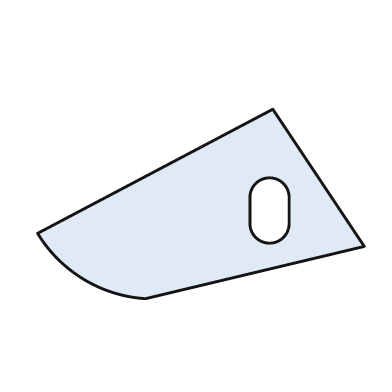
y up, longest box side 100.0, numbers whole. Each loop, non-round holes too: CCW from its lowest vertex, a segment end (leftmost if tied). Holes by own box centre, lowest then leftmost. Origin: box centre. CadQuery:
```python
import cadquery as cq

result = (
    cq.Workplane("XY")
    .moveTo(-17.0, -29.0)
    .lineTo(50.0, -13.0)
    .lineTo(22.0, 29.0)
    .lineTo(-50.0, -9.0)
    .threePointArc((-36.0, -23.0), (-17.0, -29.0))
    .close()
    .moveTo(15.0, -6.0)
    .threePointArc((21.0, -12.0), (27.0, -6.0))
    .lineTo(27.0, 2.0)
    .threePointArc((21.0, 8.0), (15.0, 2.0))
    .close()
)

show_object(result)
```